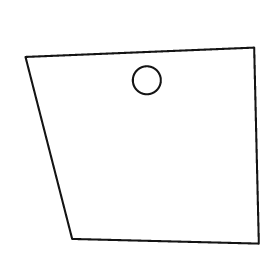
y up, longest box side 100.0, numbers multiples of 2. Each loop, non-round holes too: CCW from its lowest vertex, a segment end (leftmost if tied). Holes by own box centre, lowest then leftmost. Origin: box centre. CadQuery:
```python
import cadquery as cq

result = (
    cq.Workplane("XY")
    .moveTo(50.0, -42.0)
    .lineTo(48.0, 42.0)
    .lineTo(-50.0, 38.0)
    .lineTo(-30.0, -40.0)
    .close()
    .moveTo(2.0, 28.0)
    .circle(6.0)
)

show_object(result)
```